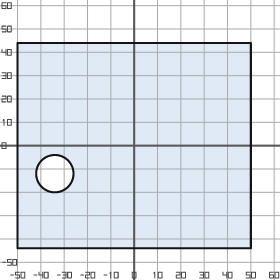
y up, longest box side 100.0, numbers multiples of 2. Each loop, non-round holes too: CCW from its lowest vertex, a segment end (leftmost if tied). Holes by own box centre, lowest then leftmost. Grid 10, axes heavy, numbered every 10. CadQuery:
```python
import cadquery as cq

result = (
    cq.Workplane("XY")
    .moveTo(-50.0, -44.0)
    .lineTo(50.0, -44.0)
    .lineTo(50.0, 44.0)
    .lineTo(-50.0, 44.0)
    .close()
    .moveTo(-34.0, -12.0)
    .circle(8.0)
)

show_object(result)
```